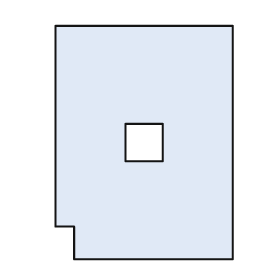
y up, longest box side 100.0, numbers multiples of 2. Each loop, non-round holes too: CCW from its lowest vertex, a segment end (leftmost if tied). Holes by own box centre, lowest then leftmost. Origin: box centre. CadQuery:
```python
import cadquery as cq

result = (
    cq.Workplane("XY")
    .moveTo(-30.0, -50.0)
    .lineTo(38.0, -50.0)
    .lineTo(38.0, 50.0)
    .lineTo(-38.0, 50.0)
    .lineTo(-38.0, -36.0)
    .lineTo(-30.0, -36.0)
    .close()
    .moveTo(-8.0, -8.0)
    .lineTo(8.0, -8.0)
    .lineTo(8.0, 8.0)
    .lineTo(-8.0, 8.0)
    .close()
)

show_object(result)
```